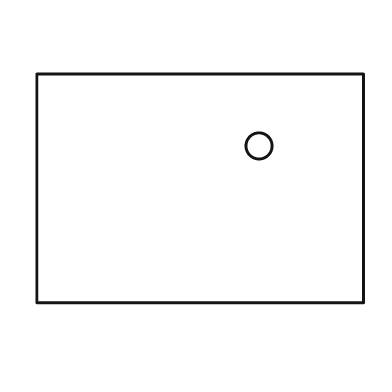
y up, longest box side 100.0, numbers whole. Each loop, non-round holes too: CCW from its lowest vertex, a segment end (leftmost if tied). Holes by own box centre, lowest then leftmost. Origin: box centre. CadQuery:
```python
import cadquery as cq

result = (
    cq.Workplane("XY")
    .moveTo(-50.0, -35.0)
    .lineTo(50.0, -35.0)
    .lineTo(50.0, 35.0)
    .lineTo(-50.0, 35.0)
    .close()
    .moveTo(18.0, 13.0)
    .circle(4.0)
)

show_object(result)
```